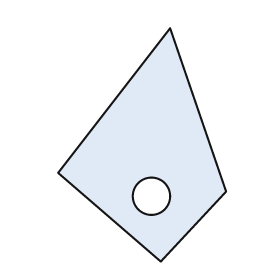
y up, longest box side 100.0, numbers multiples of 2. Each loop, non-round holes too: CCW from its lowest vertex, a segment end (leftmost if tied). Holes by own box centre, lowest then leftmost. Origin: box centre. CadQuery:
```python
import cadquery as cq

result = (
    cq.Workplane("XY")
    .moveTo(8.0, -50.0)
    .lineTo(36.0, -20.0)
    .lineTo(12.0, 50.0)
    .lineTo(-36.0, -12.0)
    .close()
    .moveTo(4.0, -22.0)
    .circle(8.0)
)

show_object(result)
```